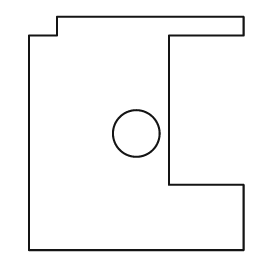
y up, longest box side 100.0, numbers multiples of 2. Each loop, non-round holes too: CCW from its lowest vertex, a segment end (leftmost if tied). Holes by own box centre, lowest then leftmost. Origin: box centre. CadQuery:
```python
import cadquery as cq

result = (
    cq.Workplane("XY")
    .moveTo(-46.0, -50.0)
    .lineTo(46.0, -50.0)
    .lineTo(46.0, -22.0)
    .lineTo(14.0, -22.0)
    .lineTo(14.0, 42.0)
    .lineTo(46.0, 42.0)
    .lineTo(46.0, 50.0)
    .lineTo(-34.0, 50.0)
    .lineTo(-34.0, 42.0)
    .lineTo(-46.0, 42.0)
    .close()
    .moveTo(0.0, 0.0)
    .circle(10.0)
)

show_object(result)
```